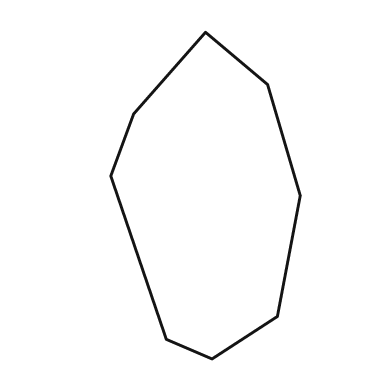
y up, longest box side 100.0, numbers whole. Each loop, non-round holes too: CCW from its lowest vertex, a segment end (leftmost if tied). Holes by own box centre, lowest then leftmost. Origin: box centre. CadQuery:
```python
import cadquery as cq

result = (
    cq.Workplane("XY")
    .moveTo(2.0, -50.0)
    .lineTo(22.0, -37.0)
    .lineTo(29.0, 0.0)
    .lineTo(19.0, 34.0)
    .lineTo(0.0, 50.0)
    .lineTo(-22.0, 25.0)
    .lineTo(-29.0, 6.0)
    .lineTo(-12.0, -44.0)
    .close()
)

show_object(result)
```